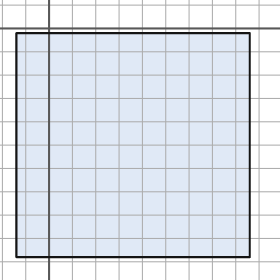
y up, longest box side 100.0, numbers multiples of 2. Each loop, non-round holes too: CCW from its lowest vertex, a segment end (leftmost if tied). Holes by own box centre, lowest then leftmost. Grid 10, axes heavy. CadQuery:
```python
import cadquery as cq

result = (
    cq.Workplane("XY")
    .moveTo(-14.0, -98.0)
    .lineTo(86.0, -98.0)
    .lineTo(86.0, -2.0)
    .lineTo(-14.0, -2.0)
    .close()
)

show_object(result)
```